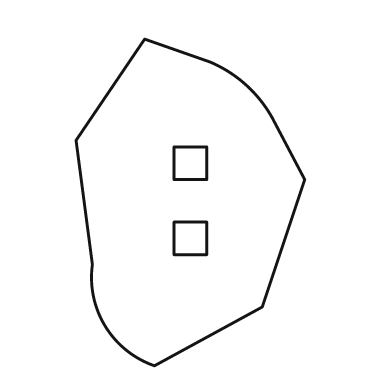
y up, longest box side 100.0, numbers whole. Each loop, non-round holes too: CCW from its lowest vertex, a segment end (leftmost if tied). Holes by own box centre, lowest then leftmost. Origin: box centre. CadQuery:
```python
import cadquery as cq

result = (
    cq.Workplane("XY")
    .moveTo(-11.0, -50.0)
    .lineTo(22.0, -32.0)
    .lineTo(35.0, 7.0)
    .lineTo(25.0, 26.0)
    .threePointArc((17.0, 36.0), (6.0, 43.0))
    .lineTo(-14.0, 50.0)
    .lineTo(-35.0, 19.0)
    .lineTo(-30.0, -19.0)
    .threePointArc((-26.0, -38.0), (-11.0, -50.0))
    .close()
    .moveTo(-5.0, -16.0)
    .lineTo(5.0, -16.0)
    .lineTo(5.0, -6.0)
    .lineTo(-5.0, -6.0)
    .close()
    .moveTo(-5.0, 7.0)
    .lineTo(5.0, 7.0)
    .lineTo(5.0, 17.0)
    .lineTo(-5.0, 17.0)
    .close()
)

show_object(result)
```